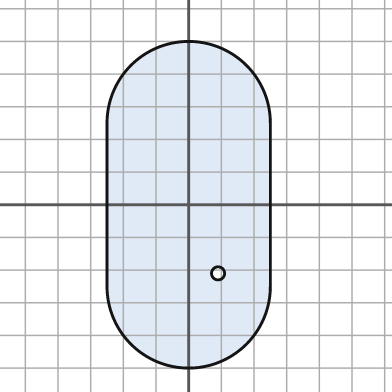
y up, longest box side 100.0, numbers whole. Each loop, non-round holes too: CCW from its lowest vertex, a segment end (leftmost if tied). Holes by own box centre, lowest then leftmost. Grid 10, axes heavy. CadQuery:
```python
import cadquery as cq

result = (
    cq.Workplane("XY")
    .moveTo(-25.0, -25.0)
    .threePointArc((0.0, -50.0), (25.0, -25.0))
    .lineTo(25.0, 25.0)
    .threePointArc((0.0, 50.0), (-25.0, 25.0))
    .close()
    .moveTo(9.0, -21.0)
    .circle(2.0)
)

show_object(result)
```